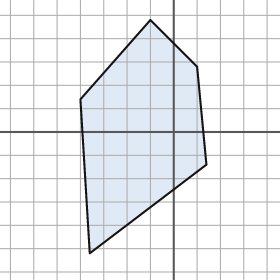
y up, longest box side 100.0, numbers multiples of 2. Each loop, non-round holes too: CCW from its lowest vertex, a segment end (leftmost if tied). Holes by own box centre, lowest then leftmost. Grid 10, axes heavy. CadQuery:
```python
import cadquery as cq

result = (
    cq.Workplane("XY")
    .moveTo(-36.0, -52.0)
    .lineTo(14.0, -14.0)
    .lineTo(10.0, 28.0)
    .lineTo(-10.0, 48.0)
    .lineTo(-40.0, 14.0)
    .close()
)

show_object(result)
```